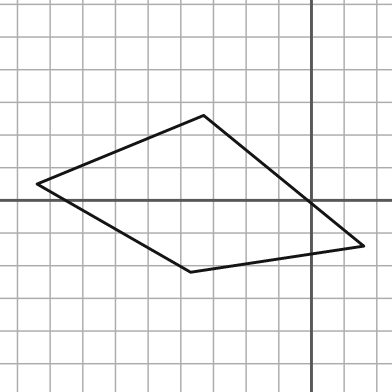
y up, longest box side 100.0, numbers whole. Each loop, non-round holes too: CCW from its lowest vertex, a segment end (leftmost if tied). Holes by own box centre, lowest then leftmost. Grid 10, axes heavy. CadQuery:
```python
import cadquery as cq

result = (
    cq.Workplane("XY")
    .moveTo(-37.0, -22.0)
    .lineTo(16.0, -14.0)
    .lineTo(-33.0, 26.0)
    .lineTo(-84.0, 5.0)
    .close()
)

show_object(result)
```